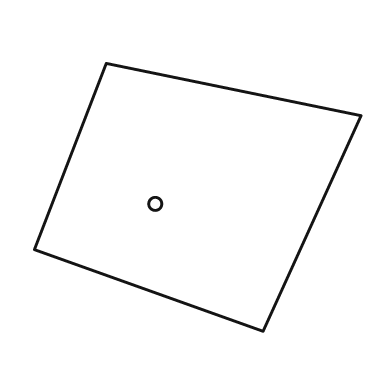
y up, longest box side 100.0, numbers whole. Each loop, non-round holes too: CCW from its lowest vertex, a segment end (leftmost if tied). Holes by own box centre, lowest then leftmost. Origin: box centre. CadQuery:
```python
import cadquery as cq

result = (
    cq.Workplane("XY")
    .moveTo(20.0, -41.0)
    .lineTo(50.0, 25.0)
    .lineTo(-28.0, 41.0)
    .lineTo(-50.0, -16.0)
    .close()
    .moveTo(-13.0, -2.0)
    .circle(2.0)
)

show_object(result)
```